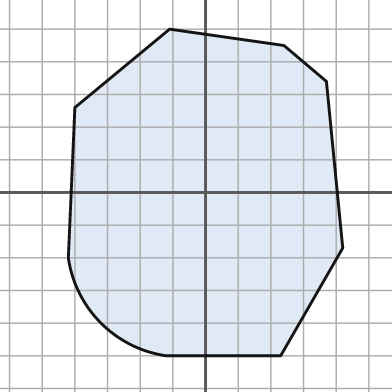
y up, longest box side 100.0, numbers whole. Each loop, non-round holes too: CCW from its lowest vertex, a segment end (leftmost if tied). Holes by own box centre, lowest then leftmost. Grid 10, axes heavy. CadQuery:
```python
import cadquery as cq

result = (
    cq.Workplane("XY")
    .moveTo(-12.0, -50.0)
    .lineTo(23.0, -50.0)
    .lineTo(42.0, -17.0)
    .lineTo(37.0, 34.0)
    .lineTo(24.0, 45.0)
    .lineTo(-11.0, 50.0)
    .lineTo(-40.0, 26.0)
    .lineTo(-42.0, -20.0)
    .threePointArc((-32.0, -40.0), (-12.0, -50.0))
    .close()
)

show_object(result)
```